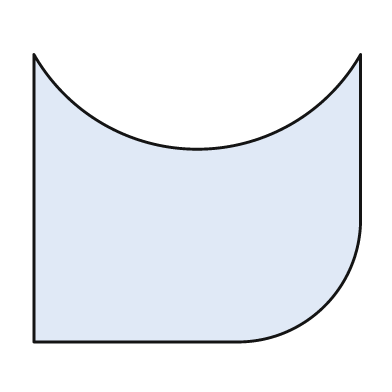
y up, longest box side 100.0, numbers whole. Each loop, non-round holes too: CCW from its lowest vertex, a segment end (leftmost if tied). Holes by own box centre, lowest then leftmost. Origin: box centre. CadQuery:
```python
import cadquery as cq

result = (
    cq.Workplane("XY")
    .moveTo(-50.0, -44.0)
    .lineTo(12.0, -44.0)
    .threePointArc((39.0, -33.0), (50.0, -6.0))
    .lineTo(50.0, 44.0)
    .threePointArc((0.0, 15.0), (-50.0, 44.0))
    .close()
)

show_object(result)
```